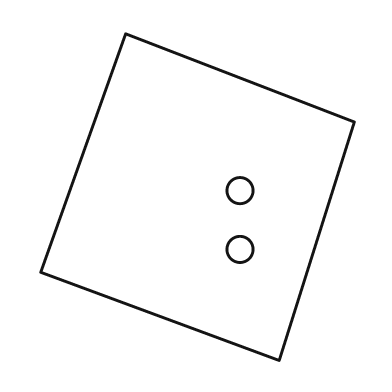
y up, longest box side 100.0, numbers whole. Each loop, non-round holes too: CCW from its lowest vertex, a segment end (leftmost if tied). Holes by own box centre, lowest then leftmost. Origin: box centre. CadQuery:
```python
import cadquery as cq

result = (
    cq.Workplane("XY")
    .moveTo(25.0, -50.0)
    .lineTo(48.0, 23.0)
    .lineTo(-22.0, 50.0)
    .lineTo(-48.0, -23.0)
    .close()
    .moveTo(13.0, -16.0)
    .circle(4.0)
    .moveTo(13.0, 2.0)
    .circle(4.0)
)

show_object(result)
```